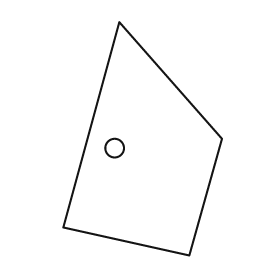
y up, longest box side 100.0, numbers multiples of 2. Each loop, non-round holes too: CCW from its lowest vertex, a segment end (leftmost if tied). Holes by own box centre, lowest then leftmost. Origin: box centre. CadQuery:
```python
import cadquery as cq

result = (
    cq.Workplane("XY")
    .moveTo(20.0, -50.0)
    .lineTo(34.0, 0.0)
    .lineTo(-10.0, 50.0)
    .lineTo(-34.0, -38.0)
    .close()
    .moveTo(-12.0, -4.0)
    .circle(4.0)
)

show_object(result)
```